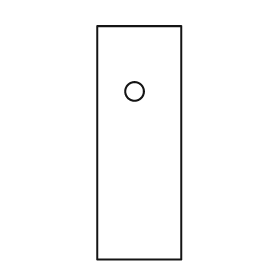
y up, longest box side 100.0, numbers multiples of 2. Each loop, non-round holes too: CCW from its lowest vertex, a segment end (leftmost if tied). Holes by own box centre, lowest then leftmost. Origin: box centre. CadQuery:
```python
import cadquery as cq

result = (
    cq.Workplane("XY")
    .moveTo(-18.0, -50.0)
    .lineTo(18.0, -50.0)
    .lineTo(18.0, 50.0)
    .lineTo(-18.0, 50.0)
    .close()
    .moveTo(-2.0, 22.0)
    .circle(4.0)
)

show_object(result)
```